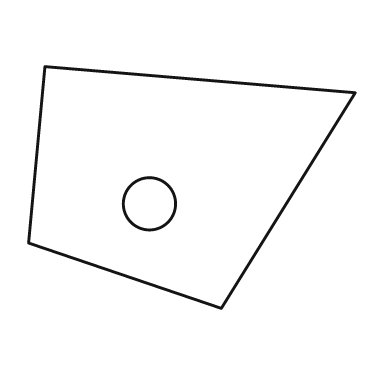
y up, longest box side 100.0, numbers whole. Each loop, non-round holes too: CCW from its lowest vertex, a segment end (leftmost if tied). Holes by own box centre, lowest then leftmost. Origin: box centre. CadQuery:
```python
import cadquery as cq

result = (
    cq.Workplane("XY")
    .moveTo(9.0, -37.0)
    .lineTo(50.0, 29.0)
    .lineTo(-45.0, 37.0)
    .lineTo(-50.0, -17.0)
    .close()
    .moveTo(-13.0, -5.0)
    .circle(8.0)
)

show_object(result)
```